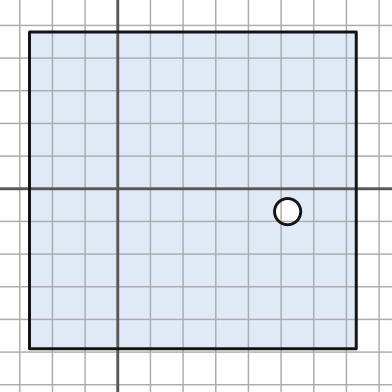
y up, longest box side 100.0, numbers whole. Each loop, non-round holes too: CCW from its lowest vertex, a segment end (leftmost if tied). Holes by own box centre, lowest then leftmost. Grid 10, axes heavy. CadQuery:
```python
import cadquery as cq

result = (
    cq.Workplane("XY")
    .moveTo(-27.0, -49.0)
    .lineTo(73.0, -49.0)
    .lineTo(73.0, 48.0)
    .lineTo(-27.0, 48.0)
    .close()
    .moveTo(52.0, -7.0)
    .circle(4.0)
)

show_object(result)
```